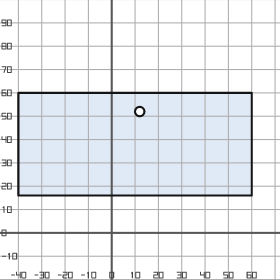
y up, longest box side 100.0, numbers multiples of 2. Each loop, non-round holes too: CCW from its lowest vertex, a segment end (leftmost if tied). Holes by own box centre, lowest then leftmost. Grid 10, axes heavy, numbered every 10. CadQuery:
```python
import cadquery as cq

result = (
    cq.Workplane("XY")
    .moveTo(-40.0, 16.0)
    .lineTo(60.0, 16.0)
    .lineTo(60.0, 60.0)
    .lineTo(-40.0, 60.0)
    .close()
    .moveTo(12.0, 52.0)
    .circle(2.0)
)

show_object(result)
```